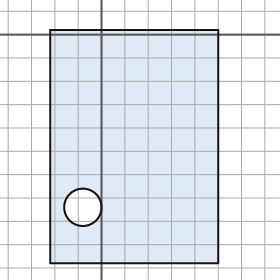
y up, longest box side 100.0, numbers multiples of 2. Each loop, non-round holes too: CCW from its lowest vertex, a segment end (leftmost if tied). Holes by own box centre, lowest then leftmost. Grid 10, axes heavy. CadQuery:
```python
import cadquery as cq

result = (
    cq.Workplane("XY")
    .moveTo(-22.0, -98.0)
    .lineTo(50.0, -98.0)
    .lineTo(50.0, 2.0)
    .lineTo(-22.0, 2.0)
    .close()
    .moveTo(-8.0, -74.0)
    .circle(8.0)
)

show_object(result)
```